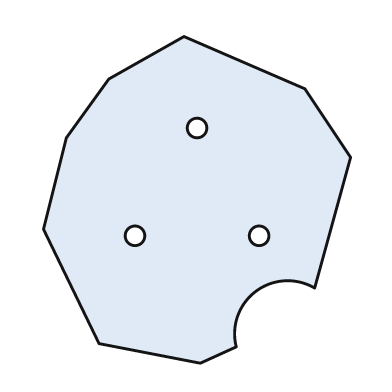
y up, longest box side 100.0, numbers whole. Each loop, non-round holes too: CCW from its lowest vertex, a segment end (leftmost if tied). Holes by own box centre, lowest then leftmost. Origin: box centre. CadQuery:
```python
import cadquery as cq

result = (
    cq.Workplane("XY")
    .moveTo(1.0, -50.0)
    .lineTo(12.0, -45.0)
    .threePointArc((18.0, -28.0), (36.0, -27.0))
    .lineTo(47.0, 13.0)
    .lineTo(33.0, 34.0)
    .lineTo(-4.0, 50.0)
    .lineTo(-27.0, 37.0)
    .lineTo(-40.0, 19.0)
    .lineTo(-47.0, -9.0)
    .lineTo(-30.0, -44.0)
    .close()
    .moveTo(-19.0, -11.0)
    .circle(3.0)
    .moveTo(19.0, -11.0)
    .circle(3.0)
    .moveTo(0.0, 22.0)
    .circle(3.0)
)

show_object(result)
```